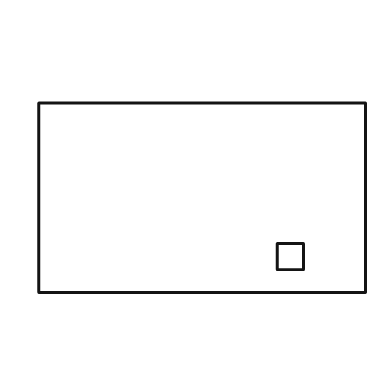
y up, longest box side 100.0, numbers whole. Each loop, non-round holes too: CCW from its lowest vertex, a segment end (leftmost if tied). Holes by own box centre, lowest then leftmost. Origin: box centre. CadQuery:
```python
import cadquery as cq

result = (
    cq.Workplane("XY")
    .moveTo(-50.0, -29.0)
    .lineTo(50.0, -29.0)
    .lineTo(50.0, 29.0)
    .lineTo(-50.0, 29.0)
    .close()
    .moveTo(23.0, -22.0)
    .lineTo(31.0, -22.0)
    .lineTo(31.0, -14.0)
    .lineTo(23.0, -14.0)
    .close()
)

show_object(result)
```